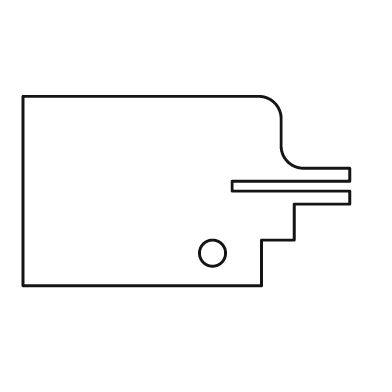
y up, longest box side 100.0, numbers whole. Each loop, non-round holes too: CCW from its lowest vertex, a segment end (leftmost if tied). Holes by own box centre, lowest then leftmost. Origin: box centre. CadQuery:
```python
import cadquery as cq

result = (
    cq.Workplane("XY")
    .moveTo(-50.0, -29.0)
    .lineTo(23.0, -29.0)
    .lineTo(23.0, -15.0)
    .lineTo(33.0, -15.0)
    .lineTo(33.0, -4.0)
    .lineTo(50.0, -4.0)
    .lineTo(50.0, 0.0)
    .lineTo(14.0, 0.0)
    .lineTo(14.0, 3.0)
    .lineTo(50.0, 3.0)
    .lineTo(50.0, 7.0)
    .lineTo(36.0, 7.0)
    .threePointArc((31.0, 9.0), (29.0, 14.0))
    .lineTo(29.0, 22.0)
    .threePointArc((27.0, 27.0), (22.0, 29.0))
    .lineTo(-50.0, 29.0)
    .close()
    .moveTo(8.0, -19.0)
    .circle(4.0)
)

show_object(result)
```